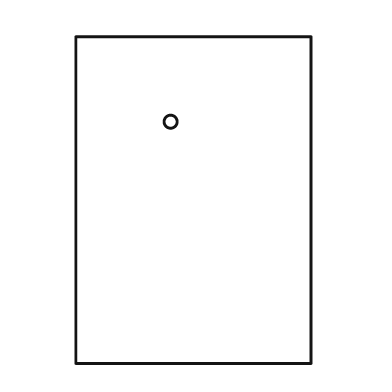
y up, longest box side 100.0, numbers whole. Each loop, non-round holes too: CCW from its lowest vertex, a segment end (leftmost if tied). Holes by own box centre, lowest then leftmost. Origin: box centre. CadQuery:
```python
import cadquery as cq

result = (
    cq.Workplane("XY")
    .moveTo(-36.0, -50.0)
    .lineTo(36.0, -50.0)
    .lineTo(36.0, 50.0)
    .lineTo(-36.0, 50.0)
    .close()
    .moveTo(-7.0, 24.0)
    .circle(2.0)
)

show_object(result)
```